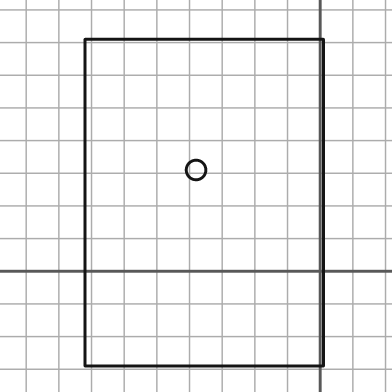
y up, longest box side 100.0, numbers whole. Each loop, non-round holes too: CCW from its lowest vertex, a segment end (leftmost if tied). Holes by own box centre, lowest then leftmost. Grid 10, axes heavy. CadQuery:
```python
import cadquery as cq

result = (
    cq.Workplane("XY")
    .moveTo(-72.0, -29.0)
    .lineTo(1.0, -29.0)
    .lineTo(1.0, 71.0)
    .lineTo(-72.0, 71.0)
    .close()
    .moveTo(-38.0, 31.0)
    .circle(3.0)
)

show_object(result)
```